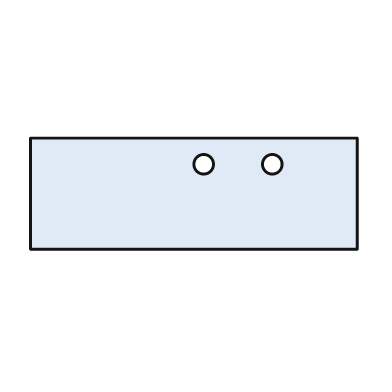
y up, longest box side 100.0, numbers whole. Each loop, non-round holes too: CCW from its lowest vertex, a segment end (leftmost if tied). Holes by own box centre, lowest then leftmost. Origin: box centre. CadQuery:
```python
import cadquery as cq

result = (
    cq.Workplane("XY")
    .moveTo(-50.0, -17.0)
    .lineTo(50.0, -17.0)
    .lineTo(50.0, 17.0)
    .lineTo(-50.0, 17.0)
    .close()
    .moveTo(3.0, 9.0)
    .circle(3.0)
    .moveTo(24.0, 9.0)
    .circle(3.0)
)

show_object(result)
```